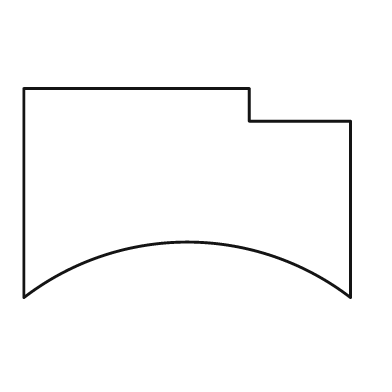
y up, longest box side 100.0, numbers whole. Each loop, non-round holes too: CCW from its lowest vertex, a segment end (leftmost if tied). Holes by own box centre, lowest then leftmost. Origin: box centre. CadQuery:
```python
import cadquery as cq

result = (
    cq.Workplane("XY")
    .moveTo(-50.0, -32.0)
    .threePointArc((0.0, -15.0), (50.0, -32.0))
    .lineTo(50.0, 22.0)
    .lineTo(19.0, 22.0)
    .lineTo(19.0, 32.0)
    .lineTo(-50.0, 32.0)
    .close()
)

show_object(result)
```